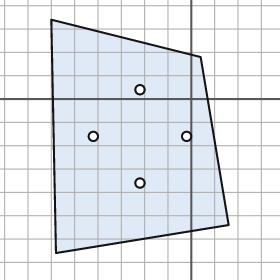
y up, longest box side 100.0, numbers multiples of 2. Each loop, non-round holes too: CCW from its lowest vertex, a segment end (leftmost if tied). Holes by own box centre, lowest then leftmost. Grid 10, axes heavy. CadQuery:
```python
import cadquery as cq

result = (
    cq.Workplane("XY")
    .moveTo(-58.0, -66.0)
    .lineTo(16.0, -54.0)
    .lineTo(4.0, 18.0)
    .lineTo(-60.0, 34.0)
    .close()
    .moveTo(-22.0, -36.0)
    .circle(2.0)
    .moveTo(-42.0, -16.0)
    .circle(2.0)
    .moveTo(-2.0, -16.0)
    .circle(2.0)
    .moveTo(-22.0, 4.0)
    .circle(2.0)
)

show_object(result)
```